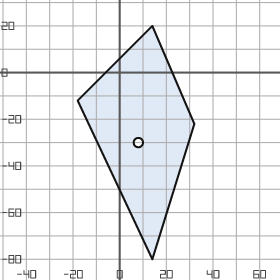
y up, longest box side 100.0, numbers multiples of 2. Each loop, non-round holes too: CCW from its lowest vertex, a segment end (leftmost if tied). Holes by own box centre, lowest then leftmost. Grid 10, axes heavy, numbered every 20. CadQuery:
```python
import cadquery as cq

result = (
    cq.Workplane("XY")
    .moveTo(14.0, -80.0)
    .lineTo(32.0, -22.0)
    .lineTo(14.0, 20.0)
    .lineTo(-18.0, -12.0)
    .close()
    .moveTo(8.0, -30.0)
    .circle(2.0)
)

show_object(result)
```